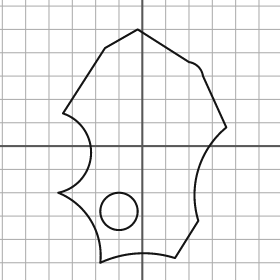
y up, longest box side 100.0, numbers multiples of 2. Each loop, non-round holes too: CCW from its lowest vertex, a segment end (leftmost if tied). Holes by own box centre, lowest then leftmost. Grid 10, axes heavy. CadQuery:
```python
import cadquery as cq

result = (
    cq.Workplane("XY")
    .moveTo(-18.0, -50.0)
    .threePointArc((-2.0, -46.0), (14.0, -48.0))
    .lineTo(24.0, -32.0)
    .threePointArc((24.0, -10.0), (36.0, 8.0))
    .lineTo(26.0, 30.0)
    .threePointArc((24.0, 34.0), (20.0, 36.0))
    .lineTo(-2.0, 50.0)
    .lineTo(-16.0, 42.0)
    .lineTo(-34.0, 14.0)
    .threePointArc((-22.0, -4.0), (-36.0, -20.0))
    .threePointArc((-22.0, -32.0), (-18.0, -50.0))
    .close()
    .moveTo(-10.0, -28.0)
    .circle(8.0)
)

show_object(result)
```